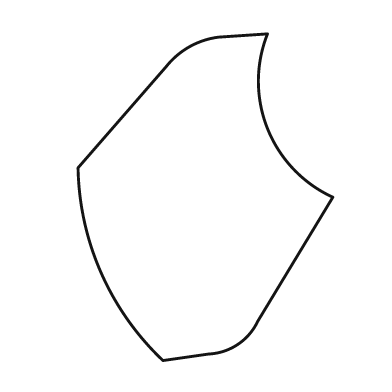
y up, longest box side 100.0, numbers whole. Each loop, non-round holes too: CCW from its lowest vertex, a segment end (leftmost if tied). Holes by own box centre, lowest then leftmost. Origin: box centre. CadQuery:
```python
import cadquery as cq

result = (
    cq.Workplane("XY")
    .moveTo(-13.0, -50.0)
    .lineTo(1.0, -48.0)
    .threePointArc((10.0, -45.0), (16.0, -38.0))
    .lineTo(39.0, 0.0)
    .threePointArc((19.0, 21.0), (19.0, 50.0))
    .lineTo(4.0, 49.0)
    .threePointArc((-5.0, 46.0), (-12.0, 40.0))
    .lineTo(-39.0, 9.0)
    .threePointArc((-32.0, -23.0), (-13.0, -50.0))
    .close()
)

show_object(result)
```